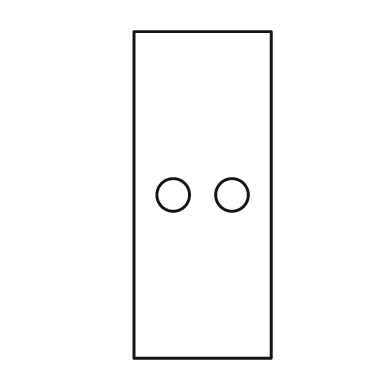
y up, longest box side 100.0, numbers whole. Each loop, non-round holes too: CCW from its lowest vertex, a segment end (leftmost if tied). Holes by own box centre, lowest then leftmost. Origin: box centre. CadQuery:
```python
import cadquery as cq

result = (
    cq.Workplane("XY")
    .moveTo(-21.0, -50.0)
    .lineTo(21.0, -50.0)
    .lineTo(21.0, 50.0)
    .lineTo(-21.0, 50.0)
    .close()
    .moveTo(-9.0, 0.0)
    .circle(5.0)
    .moveTo(9.0, 0.0)
    .circle(5.0)
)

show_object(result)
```